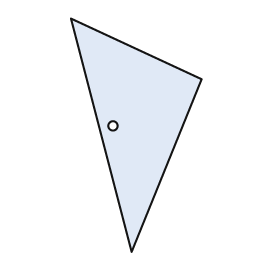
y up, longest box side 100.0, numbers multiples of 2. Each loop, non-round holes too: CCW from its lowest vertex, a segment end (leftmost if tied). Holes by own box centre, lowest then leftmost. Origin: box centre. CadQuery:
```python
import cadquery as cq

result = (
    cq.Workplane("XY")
    .moveTo(-2.0, -50.0)
    .lineTo(28.0, 24.0)
    .lineTo(-28.0, 50.0)
    .close()
    .moveTo(-10.0, 4.0)
    .circle(2.0)
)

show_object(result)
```